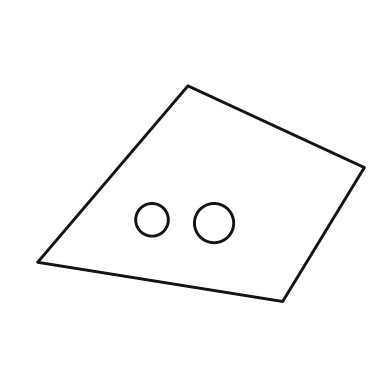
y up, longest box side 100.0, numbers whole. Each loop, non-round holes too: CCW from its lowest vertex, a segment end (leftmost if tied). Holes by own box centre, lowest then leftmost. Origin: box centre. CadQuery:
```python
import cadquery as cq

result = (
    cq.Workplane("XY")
    .moveTo(25.0, -33.0)
    .lineTo(50.0, 8.0)
    .lineTo(-4.0, 33.0)
    .lineTo(-50.0, -21.0)
    .close()
    .moveTo(4.0, -9.0)
    .circle(6.0)
    .moveTo(-15.0, -8.0)
    .circle(5.0)
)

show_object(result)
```